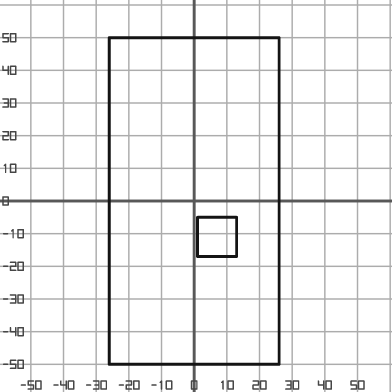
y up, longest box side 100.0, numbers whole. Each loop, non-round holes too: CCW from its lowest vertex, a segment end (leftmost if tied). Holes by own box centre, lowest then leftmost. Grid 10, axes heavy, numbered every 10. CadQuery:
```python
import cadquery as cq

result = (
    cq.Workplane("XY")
    .moveTo(-26.0, -50.0)
    .lineTo(26.0, -50.0)
    .lineTo(26.0, 50.0)
    .lineTo(-26.0, 50.0)
    .close()
    .moveTo(1.0, -17.0)
    .lineTo(13.0, -17.0)
    .lineTo(13.0, -5.0)
    .lineTo(1.0, -5.0)
    .close()
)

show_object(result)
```